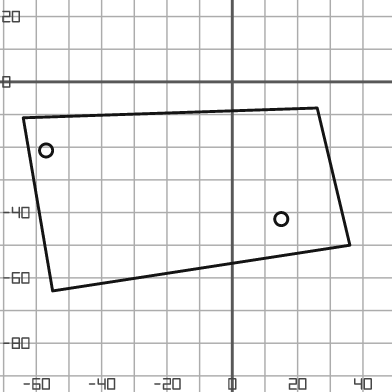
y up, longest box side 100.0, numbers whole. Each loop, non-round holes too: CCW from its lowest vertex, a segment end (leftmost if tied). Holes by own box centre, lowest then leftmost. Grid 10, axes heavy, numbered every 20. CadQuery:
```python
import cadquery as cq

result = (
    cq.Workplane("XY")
    .moveTo(-55.0, -64.0)
    .lineTo(36.0, -50.0)
    .lineTo(26.0, -8.0)
    .lineTo(-64.0, -11.0)
    .close()
    .moveTo(15.0, -42.0)
    .circle(2.0)
    .moveTo(-57.0, -21.0)
    .circle(2.0)
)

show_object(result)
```